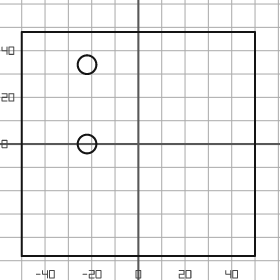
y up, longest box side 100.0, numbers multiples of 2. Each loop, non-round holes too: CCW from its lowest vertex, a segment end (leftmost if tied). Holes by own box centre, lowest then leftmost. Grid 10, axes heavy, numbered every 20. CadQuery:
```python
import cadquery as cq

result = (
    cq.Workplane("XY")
    .moveTo(-50.0, -48.0)
    .lineTo(50.0, -48.0)
    .lineTo(50.0, 48.0)
    .lineTo(-50.0, 48.0)
    .close()
    .moveTo(-22.0, 0.0)
    .circle(4.0)
    .moveTo(-22.0, 34.0)
    .circle(4.0)
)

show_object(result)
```